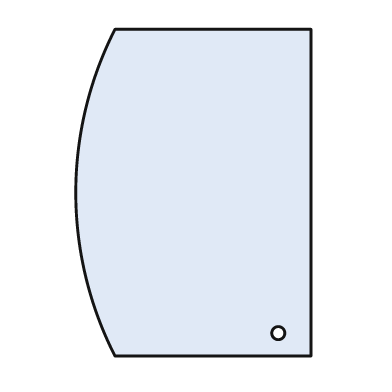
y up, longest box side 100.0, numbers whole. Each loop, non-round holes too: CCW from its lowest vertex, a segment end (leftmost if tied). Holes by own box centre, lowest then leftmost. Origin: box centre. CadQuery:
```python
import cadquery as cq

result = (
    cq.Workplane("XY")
    .moveTo(-24.0, -50.0)
    .lineTo(36.0, -50.0)
    .lineTo(36.0, 50.0)
    .lineTo(-24.0, 50.0)
    .threePointArc((-36.0, 0.0), (-24.0, -50.0))
    .close()
    .moveTo(26.0, -43.0)
    .circle(2.0)
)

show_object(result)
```